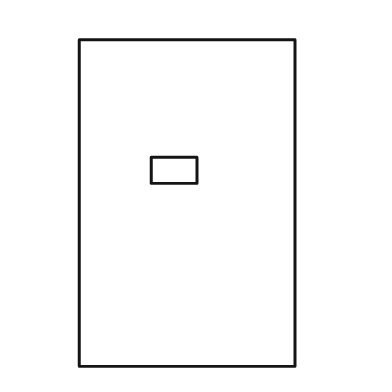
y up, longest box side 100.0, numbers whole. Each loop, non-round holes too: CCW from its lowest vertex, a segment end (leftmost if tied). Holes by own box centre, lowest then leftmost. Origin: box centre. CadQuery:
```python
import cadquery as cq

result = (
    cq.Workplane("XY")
    .moveTo(-33.0, -50.0)
    .lineTo(33.0, -50.0)
    .lineTo(33.0, 50.0)
    .lineTo(-33.0, 50.0)
    .close()
    .moveTo(-11.0, 6.0)
    .lineTo(3.0, 6.0)
    .lineTo(3.0, 14.0)
    .lineTo(-11.0, 14.0)
    .close()
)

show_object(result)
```